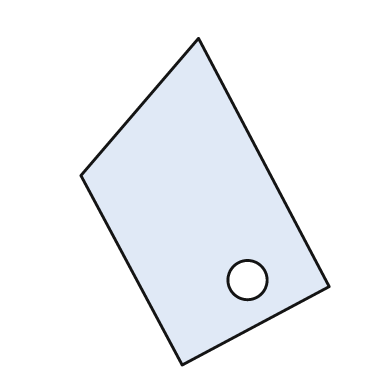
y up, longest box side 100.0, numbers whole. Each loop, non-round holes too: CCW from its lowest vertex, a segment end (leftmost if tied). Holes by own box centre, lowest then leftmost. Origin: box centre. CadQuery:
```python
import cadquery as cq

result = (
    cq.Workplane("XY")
    .moveTo(-7.0, -50.0)
    .lineTo(38.0, -26.0)
    .lineTo(-2.0, 50.0)
    .lineTo(-38.0, 8.0)
    .close()
    .moveTo(13.0, -24.0)
    .circle(6.0)
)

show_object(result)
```